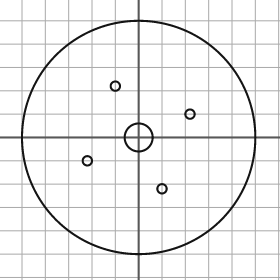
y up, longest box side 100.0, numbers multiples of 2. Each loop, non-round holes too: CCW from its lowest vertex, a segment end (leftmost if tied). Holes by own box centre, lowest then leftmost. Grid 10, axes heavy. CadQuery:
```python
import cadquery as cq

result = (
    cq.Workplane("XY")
    .moveTo(0.0, 0.0)
    .circle(50.0)
    .moveTo(10.0, -22.0)
    .circle(2.0)
    .moveTo(-22.0, -10.0)
    .circle(2.0)
    .moveTo(0.0, 0.0)
    .circle(6.0)
    .moveTo(22.0, 10.0)
    .circle(2.0)
    .moveTo(-10.0, 22.0)
    .circle(2.0)
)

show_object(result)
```